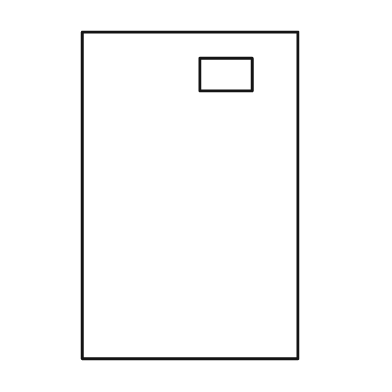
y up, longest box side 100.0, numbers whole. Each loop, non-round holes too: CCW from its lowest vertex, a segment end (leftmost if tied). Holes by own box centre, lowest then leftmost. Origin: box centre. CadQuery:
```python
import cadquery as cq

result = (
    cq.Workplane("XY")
    .moveTo(-33.0, -50.0)
    .lineTo(33.0, -50.0)
    .lineTo(33.0, 50.0)
    .lineTo(-33.0, 50.0)
    .close()
    .moveTo(3.0, 32.0)
    .lineTo(19.0, 32.0)
    .lineTo(19.0, 42.0)
    .lineTo(3.0, 42.0)
    .close()
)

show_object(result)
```